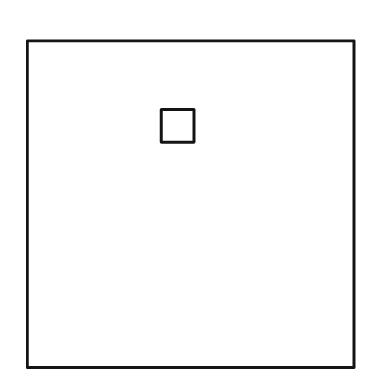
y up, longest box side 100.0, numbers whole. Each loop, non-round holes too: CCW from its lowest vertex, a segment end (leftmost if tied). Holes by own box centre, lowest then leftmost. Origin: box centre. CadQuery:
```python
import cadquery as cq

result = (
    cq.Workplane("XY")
    .moveTo(-50.0, -50.0)
    .lineTo(50.0, -50.0)
    .lineTo(50.0, 50.0)
    .lineTo(-50.0, 50.0)
    .close()
    .moveTo(-9.0, 19.0)
    .lineTo(1.0, 19.0)
    .lineTo(1.0, 29.0)
    .lineTo(-9.0, 29.0)
    .close()
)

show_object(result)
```